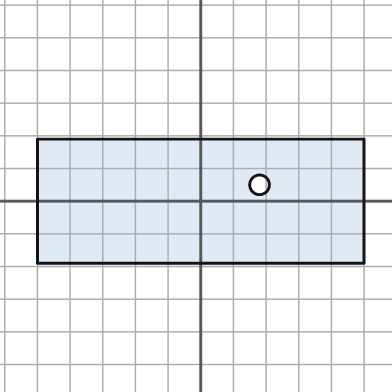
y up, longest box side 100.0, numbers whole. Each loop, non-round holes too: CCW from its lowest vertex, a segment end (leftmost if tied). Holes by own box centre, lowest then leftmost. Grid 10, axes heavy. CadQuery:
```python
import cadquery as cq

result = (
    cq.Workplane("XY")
    .moveTo(-50.0, -19.0)
    .lineTo(50.0, -19.0)
    .lineTo(50.0, 19.0)
    .lineTo(-50.0, 19.0)
    .close()
    .moveTo(18.0, 5.0)
    .circle(3.0)
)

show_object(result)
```